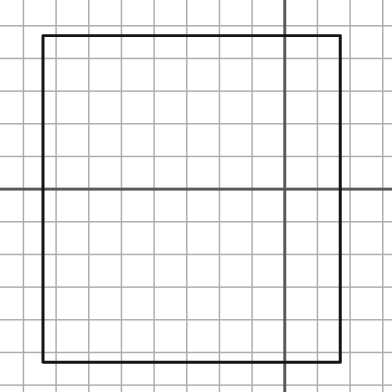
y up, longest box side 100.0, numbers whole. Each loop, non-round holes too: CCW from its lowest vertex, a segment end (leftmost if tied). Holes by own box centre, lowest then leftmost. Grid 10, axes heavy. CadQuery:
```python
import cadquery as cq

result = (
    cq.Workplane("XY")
    .moveTo(-74.0, -53.0)
    .lineTo(17.0, -53.0)
    .lineTo(17.0, 47.0)
    .lineTo(-74.0, 47.0)
    .close()
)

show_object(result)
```